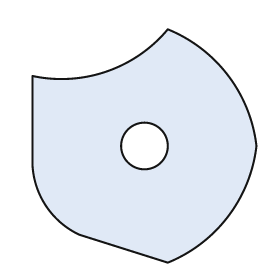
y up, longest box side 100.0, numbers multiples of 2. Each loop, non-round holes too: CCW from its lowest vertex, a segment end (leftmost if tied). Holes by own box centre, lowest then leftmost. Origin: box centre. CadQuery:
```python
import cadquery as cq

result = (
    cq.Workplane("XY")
    .moveTo(10.0, -50.0)
    .threePointArc((36.0, -30.0), (48.0, 0.0))
    .threePointArc((36.0, 30.0), (10.0, 50.0))
    .threePointArc((-16.0, 32.0), (-48.0, 30.0))
    .lineTo(-48.0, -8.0)
    .threePointArc((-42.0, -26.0), (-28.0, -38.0))
    .close()
    .moveTo(0.0, 0.0)
    .circle(10.0)
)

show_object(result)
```